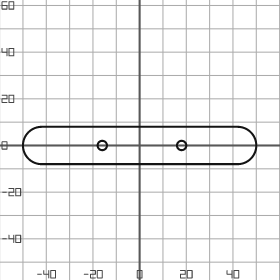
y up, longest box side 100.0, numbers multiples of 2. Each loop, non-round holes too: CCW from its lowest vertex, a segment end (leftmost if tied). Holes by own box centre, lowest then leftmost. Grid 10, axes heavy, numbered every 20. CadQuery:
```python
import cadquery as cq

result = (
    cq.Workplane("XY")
    .moveTo(-42.0, -8.0)
    .lineTo(42.0, -8.0)
    .threePointArc((50.0, 0.0), (42.0, 8.0))
    .lineTo(-42.0, 8.0)
    .threePointArc((-50.0, 0.0), (-42.0, -8.0))
    .close()
    .moveTo(-16.0, 0.0)
    .circle(2.0)
    .moveTo(18.0, 0.0)
    .circle(2.0)
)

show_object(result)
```